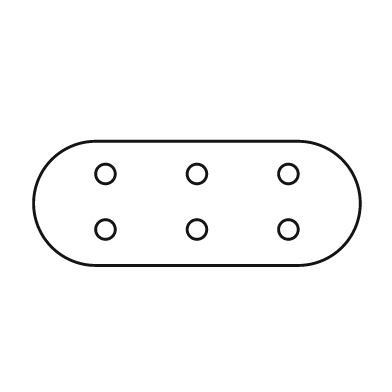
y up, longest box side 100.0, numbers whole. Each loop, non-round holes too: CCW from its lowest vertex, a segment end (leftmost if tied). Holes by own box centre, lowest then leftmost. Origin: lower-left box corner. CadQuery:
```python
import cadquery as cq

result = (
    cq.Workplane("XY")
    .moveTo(19.0, 0.0)
    .lineTo(81.0, 0.0)
    .threePointArc((100.0, 19.0), (81.0, 38.0))
    .lineTo(19.0, 38.0)
    .threePointArc((0.0, 19.0), (19.0, 0.0))
    .close()
    .moveTo(22.0, 11.0)
    .circle(3.0)
    .moveTo(50.0, 11.0)
    .circle(3.0)
    .moveTo(78.0, 11.0)
    .circle(3.0)
    .moveTo(22.0, 28.0)
    .circle(3.0)
    .moveTo(50.0, 28.0)
    .circle(3.0)
    .moveTo(78.0, 28.0)
    .circle(3.0)
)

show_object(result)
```